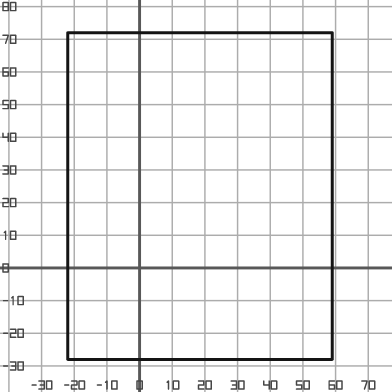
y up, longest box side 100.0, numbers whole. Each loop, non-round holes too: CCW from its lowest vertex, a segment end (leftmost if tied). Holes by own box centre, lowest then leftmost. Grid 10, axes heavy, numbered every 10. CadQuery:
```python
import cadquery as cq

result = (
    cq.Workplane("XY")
    .moveTo(-22.0, -28.0)
    .lineTo(59.0, -28.0)
    .lineTo(59.0, 72.0)
    .lineTo(-22.0, 72.0)
    .close()
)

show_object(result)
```